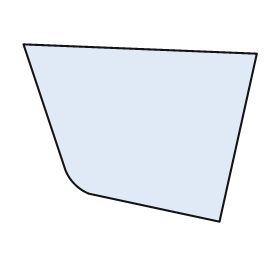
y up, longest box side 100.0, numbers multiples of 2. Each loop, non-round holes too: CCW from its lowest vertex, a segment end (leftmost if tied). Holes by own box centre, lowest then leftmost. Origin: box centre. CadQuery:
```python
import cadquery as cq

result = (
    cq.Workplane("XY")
    .moveTo(34.0, -38.0)
    .lineTo(50.0, 34.0)
    .lineTo(-50.0, 38.0)
    .lineTo(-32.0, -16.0)
    .threePointArc((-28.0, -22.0), (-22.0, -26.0))
    .close()
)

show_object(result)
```